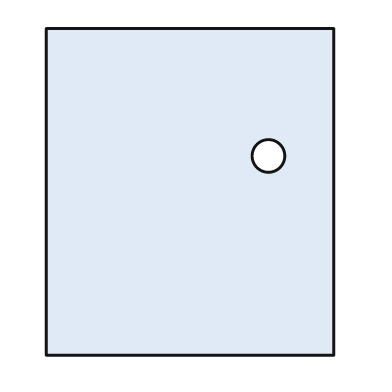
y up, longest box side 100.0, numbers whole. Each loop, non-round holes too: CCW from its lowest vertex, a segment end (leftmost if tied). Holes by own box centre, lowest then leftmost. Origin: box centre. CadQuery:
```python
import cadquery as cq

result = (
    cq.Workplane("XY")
    .moveTo(-44.0, -50.0)
    .lineTo(44.0, -50.0)
    .lineTo(44.0, 50.0)
    .lineTo(-44.0, 50.0)
    .close()
    .moveTo(24.0, 11.0)
    .circle(5.0)
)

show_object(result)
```